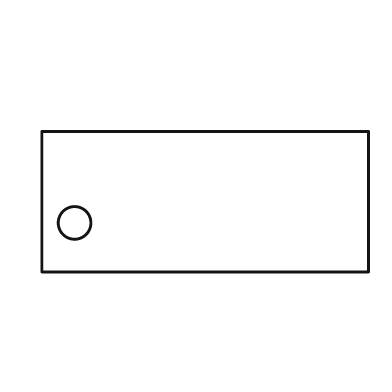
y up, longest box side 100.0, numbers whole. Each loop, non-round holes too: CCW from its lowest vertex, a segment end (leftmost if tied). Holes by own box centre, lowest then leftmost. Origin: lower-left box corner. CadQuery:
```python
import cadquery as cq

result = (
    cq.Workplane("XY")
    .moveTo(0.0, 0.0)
    .lineTo(100.0, 0.0)
    .lineTo(100.0, 43.0)
    .lineTo(0.0, 43.0)
    .close()
    .moveTo(10.0, 15.0)
    .circle(5.0)
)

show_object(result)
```